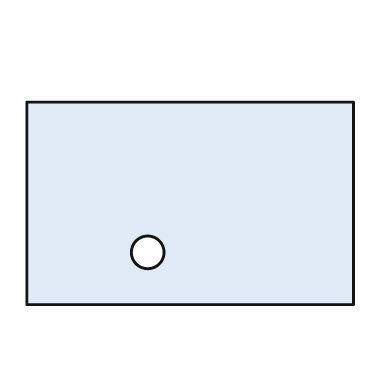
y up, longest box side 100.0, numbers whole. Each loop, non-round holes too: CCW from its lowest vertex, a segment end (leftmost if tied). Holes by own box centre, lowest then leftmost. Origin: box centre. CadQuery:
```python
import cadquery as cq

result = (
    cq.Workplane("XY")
    .moveTo(-50.0, -31.0)
    .lineTo(50.0, -31.0)
    .lineTo(50.0, 31.0)
    .lineTo(-50.0, 31.0)
    .close()
    .moveTo(-13.0, -15.0)
    .circle(5.0)
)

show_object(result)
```